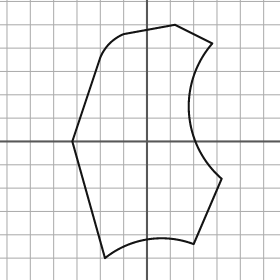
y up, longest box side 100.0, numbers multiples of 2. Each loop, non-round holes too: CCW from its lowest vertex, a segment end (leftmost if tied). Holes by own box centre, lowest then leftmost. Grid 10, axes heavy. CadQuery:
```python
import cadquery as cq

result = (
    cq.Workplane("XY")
    .moveTo(-18.0, -50.0)
    .threePointArc((0.0, -42.0), (20.0, -44.0))
    .lineTo(32.0, -16.0)
    .threePointArc((18.0, 12.0), (28.0, 42.0))
    .lineTo(12.0, 50.0)
    .lineTo(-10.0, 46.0)
    .threePointArc((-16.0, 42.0), (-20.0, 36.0))
    .lineTo(-32.0, 0.0)
    .close()
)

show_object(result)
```